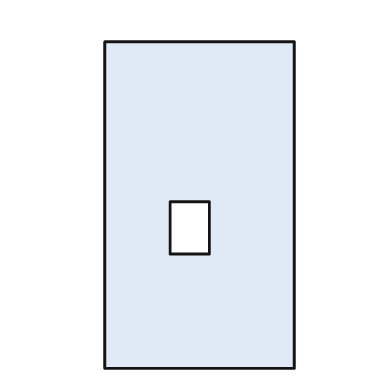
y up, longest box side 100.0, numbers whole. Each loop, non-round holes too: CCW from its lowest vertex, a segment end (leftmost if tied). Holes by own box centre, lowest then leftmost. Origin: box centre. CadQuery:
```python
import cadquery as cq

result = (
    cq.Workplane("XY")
    .moveTo(-29.0, -50.0)
    .lineTo(29.0, -50.0)
    .lineTo(29.0, 50.0)
    .lineTo(-29.0, 50.0)
    .close()
    .moveTo(-9.0, -15.0)
    .lineTo(3.0, -15.0)
    .lineTo(3.0, 1.0)
    .lineTo(-9.0, 1.0)
    .close()
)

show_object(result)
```